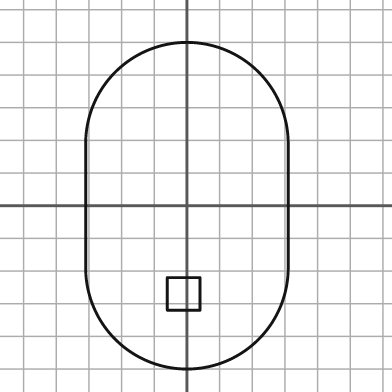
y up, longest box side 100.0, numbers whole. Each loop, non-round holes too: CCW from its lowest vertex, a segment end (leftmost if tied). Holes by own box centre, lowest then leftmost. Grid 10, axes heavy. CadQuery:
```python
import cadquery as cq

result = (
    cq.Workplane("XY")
    .moveTo(-31.0, -19.0)
    .threePointArc((0.0, -50.0), (31.0, -19.0))
    .lineTo(31.0, 19.0)
    .threePointArc((0.0, 50.0), (-31.0, 19.0))
    .close()
    .moveTo(-6.0, -32.0)
    .lineTo(4.0, -32.0)
    .lineTo(4.0, -22.0)
    .lineTo(-6.0, -22.0)
    .close()
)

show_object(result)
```